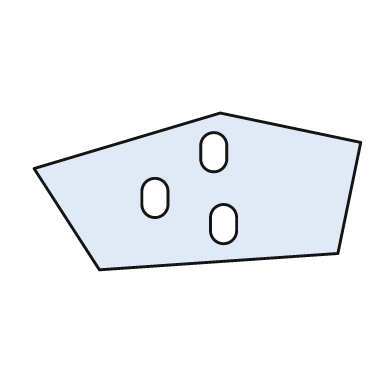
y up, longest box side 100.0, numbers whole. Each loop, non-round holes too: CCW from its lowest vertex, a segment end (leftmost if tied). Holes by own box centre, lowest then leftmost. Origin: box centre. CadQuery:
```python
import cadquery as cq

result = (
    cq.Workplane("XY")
    .moveTo(-30.0, -24.0)
    .lineTo(43.0, -19.0)
    .lineTo(50.0, 15.0)
    .lineTo(7.0, 24.0)
    .lineTo(-50.0, 7.0)
    .close()
    .moveTo(4.0, -12.0)
    .threePointArc((8.0, -16.0), (12.0, -12.0))
    .lineTo(12.0, -8.0)
    .threePointArc((8.0, -4.0), (4.0, -8.0))
    .close()
    .moveTo(-17.0, -4.0)
    .threePointArc((-13.0, -8.0), (-9.0, -4.0))
    .lineTo(-9.0, 0.0)
    .threePointArc((-13.0, 4.0), (-17.0, 0.0))
    .close()
    .moveTo(1.0, 10.0)
    .threePointArc((5.0, 6.0), (9.0, 10.0))
    .lineTo(9.0, 14.0)
    .threePointArc((5.0, 18.0), (1.0, 14.0))
    .close()
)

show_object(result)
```